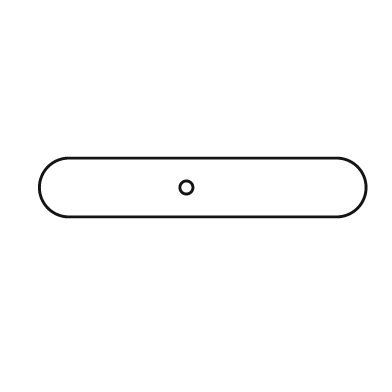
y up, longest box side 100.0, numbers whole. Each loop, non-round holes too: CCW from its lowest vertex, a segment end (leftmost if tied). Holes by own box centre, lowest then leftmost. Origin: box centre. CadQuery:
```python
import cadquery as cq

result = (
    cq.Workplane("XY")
    .moveTo(-41.0, -9.0)
    .lineTo(41.0, -9.0)
    .threePointArc((50.0, 0.0), (41.0, 9.0))
    .lineTo(-41.0, 9.0)
    .threePointArc((-50.0, 0.0), (-41.0, -9.0))
    .close()
    .moveTo(-5.0, 0.0)
    .circle(2.0)
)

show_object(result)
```